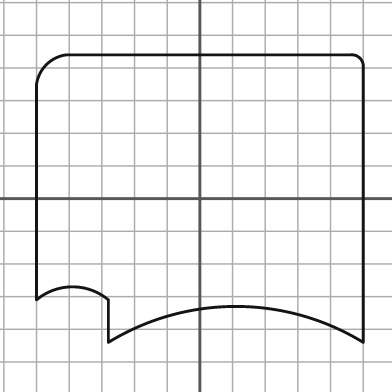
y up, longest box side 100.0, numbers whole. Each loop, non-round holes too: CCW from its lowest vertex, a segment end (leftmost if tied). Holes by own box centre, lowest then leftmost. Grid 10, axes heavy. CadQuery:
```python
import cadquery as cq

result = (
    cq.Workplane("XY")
    .moveTo(-28.0, -44.0)
    .threePointArc((11.0, -33.0), (50.0, -44.0))
    .lineTo(50.0, 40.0)
    .threePointArc((49.0, 43.0), (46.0, 44.0))
    .lineTo(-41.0, 44.0)
    .threePointArc((-47.0, 41.0), (-50.0, 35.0))
    .lineTo(-50.0, -31.0)
    .threePointArc((-39.0, -27.0), (-28.0, -31.0))
    .close()
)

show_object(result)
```